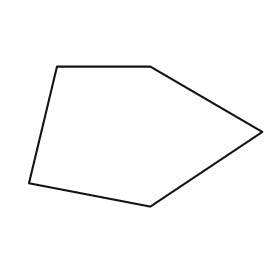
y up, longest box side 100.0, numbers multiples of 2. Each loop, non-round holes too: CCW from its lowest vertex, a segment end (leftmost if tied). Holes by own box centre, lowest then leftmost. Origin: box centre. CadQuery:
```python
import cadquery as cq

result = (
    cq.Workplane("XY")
    .moveTo(2.0, -30.0)
    .lineTo(50.0, 2.0)
    .lineTo(2.0, 30.0)
    .lineTo(-38.0, 30.0)
    .lineTo(-50.0, -20.0)
    .close()
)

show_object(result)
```